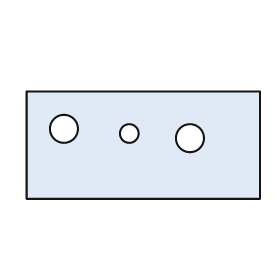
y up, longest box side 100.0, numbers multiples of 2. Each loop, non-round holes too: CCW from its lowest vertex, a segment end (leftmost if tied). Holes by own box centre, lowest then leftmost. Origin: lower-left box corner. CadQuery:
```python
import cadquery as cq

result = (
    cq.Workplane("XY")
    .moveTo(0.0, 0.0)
    .lineTo(100.0, 0.0)
    .lineTo(100.0, 46.0)
    .lineTo(0.0, 46.0)
    .close()
    .moveTo(70.0, 26.0)
    .circle(6.0)
    .moveTo(44.0, 28.0)
    .circle(4.0)
    .moveTo(16.0, 30.0)
    .circle(6.0)
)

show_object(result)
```